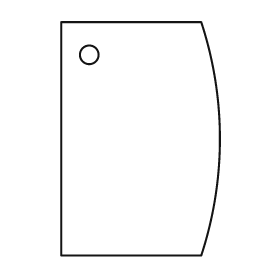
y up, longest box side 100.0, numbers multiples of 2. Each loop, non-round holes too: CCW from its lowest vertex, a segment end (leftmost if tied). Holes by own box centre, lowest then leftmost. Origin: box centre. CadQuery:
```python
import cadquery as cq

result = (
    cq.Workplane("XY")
    .moveTo(-34.0, -50.0)
    .lineTo(26.0, -50.0)
    .threePointArc((34.0, 0.0), (26.0, 50.0))
    .lineTo(-34.0, 50.0)
    .close()
    .moveTo(-22.0, 36.0)
    .circle(4.0)
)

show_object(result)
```